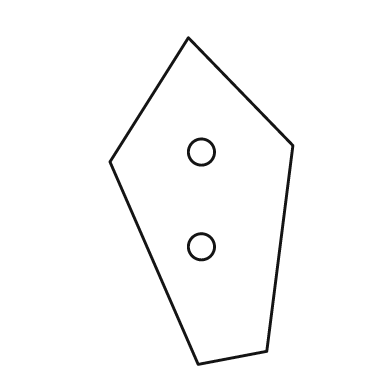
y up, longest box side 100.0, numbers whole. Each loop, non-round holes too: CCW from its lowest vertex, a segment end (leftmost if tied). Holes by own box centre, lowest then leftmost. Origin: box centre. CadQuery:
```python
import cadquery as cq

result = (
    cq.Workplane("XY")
    .moveTo(-1.0, -50.0)
    .lineTo(20.0, -46.0)
    .lineTo(28.0, 17.0)
    .lineTo(-4.0, 50.0)
    .lineTo(-28.0, 12.0)
    .close()
    .moveTo(0.0, -14.0)
    .circle(4.0)
    .moveTo(0.0, 15.0)
    .circle(4.0)
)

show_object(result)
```